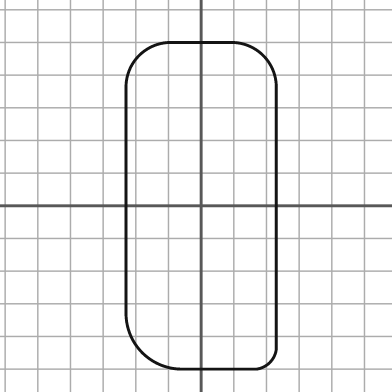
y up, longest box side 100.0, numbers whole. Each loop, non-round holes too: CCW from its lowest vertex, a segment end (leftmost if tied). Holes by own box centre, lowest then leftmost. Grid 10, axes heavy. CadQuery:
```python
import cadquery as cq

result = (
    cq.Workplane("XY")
    .moveTo(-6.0, -50.0)
    .lineTo(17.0, -50.0)
    .threePointArc((21.0, -48.0), (23.0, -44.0))
    .lineTo(23.0, 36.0)
    .threePointArc((19.0, 46.0), (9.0, 50.0))
    .lineTo(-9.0, 50.0)
    .threePointArc((-19.0, 46.0), (-23.0, 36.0))
    .lineTo(-23.0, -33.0)
    .threePointArc((-18.0, -45.0), (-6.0, -50.0))
    .close()
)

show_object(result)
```